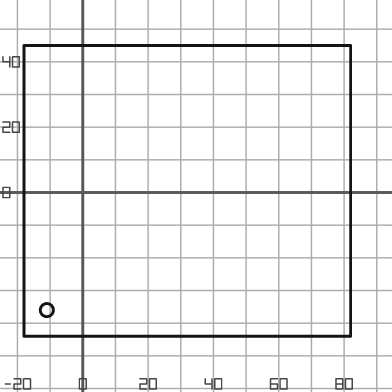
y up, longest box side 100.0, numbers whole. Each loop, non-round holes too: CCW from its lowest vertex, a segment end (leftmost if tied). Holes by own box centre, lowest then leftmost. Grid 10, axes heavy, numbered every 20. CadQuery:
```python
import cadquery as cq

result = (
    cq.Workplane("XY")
    .moveTo(-18.0, -44.0)
    .lineTo(82.0, -44.0)
    .lineTo(82.0, 45.0)
    .lineTo(-18.0, 45.0)
    .close()
    .moveTo(-11.0, -36.0)
    .circle(2.0)
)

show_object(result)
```